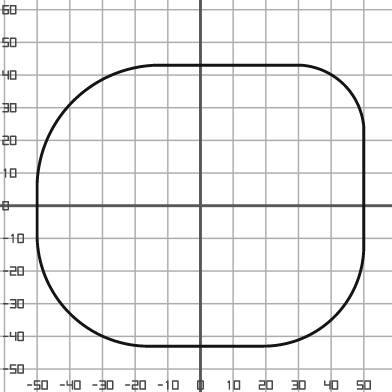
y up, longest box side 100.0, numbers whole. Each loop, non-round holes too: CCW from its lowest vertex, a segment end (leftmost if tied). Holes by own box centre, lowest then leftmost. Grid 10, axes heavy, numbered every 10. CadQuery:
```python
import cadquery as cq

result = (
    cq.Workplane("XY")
    .moveTo(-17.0, -43.0)
    .lineTo(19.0, -43.0)
    .threePointArc((41.0, -34.0), (50.0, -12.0))
    .lineTo(50.0, 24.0)
    .threePointArc((44.0, 37.0), (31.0, 43.0))
    .lineTo(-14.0, 43.0)
    .threePointArc((-39.0, 32.0), (-50.0, 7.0))
    .lineTo(-50.0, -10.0)
    .threePointArc((-40.0, -33.0), (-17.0, -43.0))
    .close()
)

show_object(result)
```